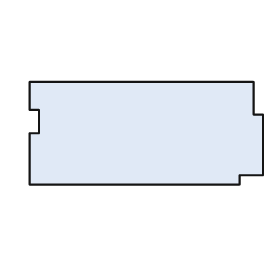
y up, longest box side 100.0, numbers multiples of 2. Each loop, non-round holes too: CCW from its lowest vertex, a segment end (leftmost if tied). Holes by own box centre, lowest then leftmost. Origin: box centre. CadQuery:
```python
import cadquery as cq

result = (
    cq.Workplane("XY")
    .moveTo(-50.0, -22.0)
    .lineTo(40.0, -22.0)
    .lineTo(40.0, -18.0)
    .lineTo(50.0, -18.0)
    .lineTo(50.0, 8.0)
    .lineTo(46.0, 8.0)
    .lineTo(46.0, 22.0)
    .lineTo(-50.0, 22.0)
    .lineTo(-50.0, 10.0)
    .lineTo(-46.0, 10.0)
    .lineTo(-46.0, 0.0)
    .lineTo(-50.0, 0.0)
    .close()
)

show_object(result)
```